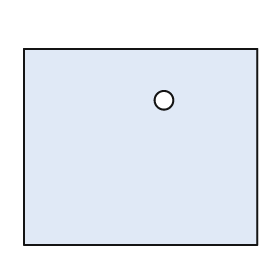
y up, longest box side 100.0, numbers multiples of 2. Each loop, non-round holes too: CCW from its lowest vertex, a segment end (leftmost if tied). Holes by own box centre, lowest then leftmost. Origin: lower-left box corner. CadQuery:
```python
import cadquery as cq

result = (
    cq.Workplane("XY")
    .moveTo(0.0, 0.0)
    .lineTo(100.0, 0.0)
    .lineTo(100.0, 84.0)
    .lineTo(0.0, 84.0)
    .close()
    .moveTo(60.0, 62.0)
    .circle(4.0)
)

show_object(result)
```